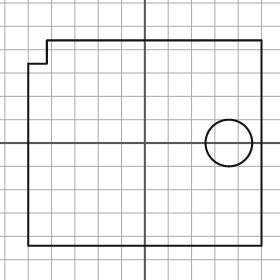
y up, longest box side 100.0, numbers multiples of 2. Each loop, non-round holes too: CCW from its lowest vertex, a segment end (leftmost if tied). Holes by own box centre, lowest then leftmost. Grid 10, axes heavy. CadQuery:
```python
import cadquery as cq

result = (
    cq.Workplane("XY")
    .moveTo(-50.0, -44.0)
    .lineTo(50.0, -44.0)
    .lineTo(50.0, 44.0)
    .lineTo(-42.0, 44.0)
    .lineTo(-42.0, 34.0)
    .lineTo(-50.0, 34.0)
    .close()
    .moveTo(36.0, 0.0)
    .circle(10.0)
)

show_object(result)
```